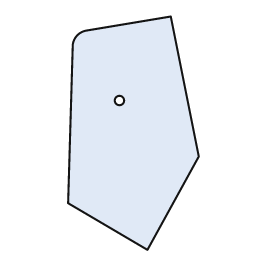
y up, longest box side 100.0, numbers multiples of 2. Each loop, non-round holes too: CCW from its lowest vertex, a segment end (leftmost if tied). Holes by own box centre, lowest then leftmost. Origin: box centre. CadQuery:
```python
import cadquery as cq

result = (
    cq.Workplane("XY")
    .moveTo(6.0, -50.0)
    .lineTo(28.0, -10.0)
    .lineTo(16.0, 50.0)
    .lineTo(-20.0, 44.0)
    .threePointArc((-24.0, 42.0), (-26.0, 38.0))
    .lineTo(-28.0, -30.0)
    .close()
    .moveTo(-6.0, 14.0)
    .circle(2.0)
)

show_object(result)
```